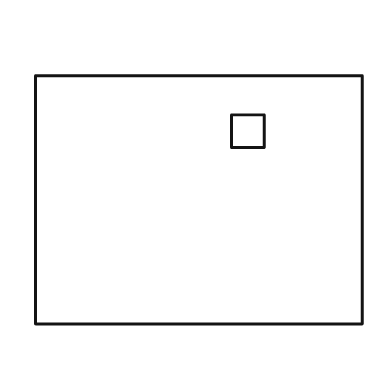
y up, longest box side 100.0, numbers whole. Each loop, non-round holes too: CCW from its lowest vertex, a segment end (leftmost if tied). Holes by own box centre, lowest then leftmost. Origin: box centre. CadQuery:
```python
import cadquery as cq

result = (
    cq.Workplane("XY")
    .moveTo(-50.0, -38.0)
    .lineTo(50.0, -38.0)
    .lineTo(50.0, 38.0)
    .lineTo(-50.0, 38.0)
    .close()
    .moveTo(10.0, 16.0)
    .lineTo(20.0, 16.0)
    .lineTo(20.0, 26.0)
    .lineTo(10.0, 26.0)
    .close()
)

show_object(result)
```